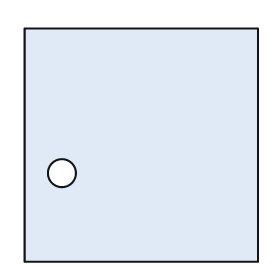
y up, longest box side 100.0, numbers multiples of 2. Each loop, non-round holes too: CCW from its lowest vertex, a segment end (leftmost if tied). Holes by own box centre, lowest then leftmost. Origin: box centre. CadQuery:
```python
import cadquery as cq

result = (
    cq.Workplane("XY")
    .moveTo(-50.0, -50.0)
    .lineTo(50.0, -50.0)
    .lineTo(50.0, 50.0)
    .lineTo(-50.0, 50.0)
    .close()
    .moveTo(-34.0, -12.0)
    .circle(6.0)
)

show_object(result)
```